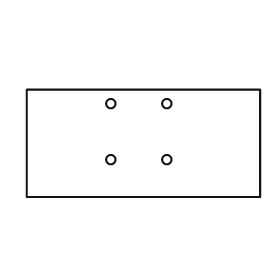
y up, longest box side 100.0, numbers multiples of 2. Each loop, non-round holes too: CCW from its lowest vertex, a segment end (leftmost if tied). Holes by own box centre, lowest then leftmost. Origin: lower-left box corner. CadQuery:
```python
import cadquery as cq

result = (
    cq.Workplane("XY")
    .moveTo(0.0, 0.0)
    .lineTo(100.0, 0.0)
    .lineTo(100.0, 46.0)
    .lineTo(0.0, 46.0)
    .close()
    .moveTo(36.0, 16.0)
    .circle(2.0)
    .moveTo(60.0, 16.0)
    .circle(2.0)
    .moveTo(36.0, 40.0)
    .circle(2.0)
    .moveTo(60.0, 40.0)
    .circle(2.0)
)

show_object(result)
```